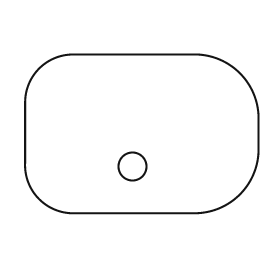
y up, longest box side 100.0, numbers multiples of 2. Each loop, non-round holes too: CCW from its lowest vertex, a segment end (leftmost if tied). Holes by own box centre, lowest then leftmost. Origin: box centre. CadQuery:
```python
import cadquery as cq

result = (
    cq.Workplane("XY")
    .moveTo(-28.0, -34.0)
    .lineTo(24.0, -34.0)
    .threePointArc((42.0, -26.0), (50.0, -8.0))
    .lineTo(50.0, 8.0)
    .threePointArc((42.0, 26.0), (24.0, 34.0))
    .lineTo(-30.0, 34.0)
    .threePointArc((-44.0, 28.0), (-50.0, 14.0))
    .lineTo(-50.0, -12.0)
    .threePointArc((-44.0, -28.0), (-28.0, -34.0))
    .close()
    .moveTo(-4.0, -14.0)
    .circle(6.0)
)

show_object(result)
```